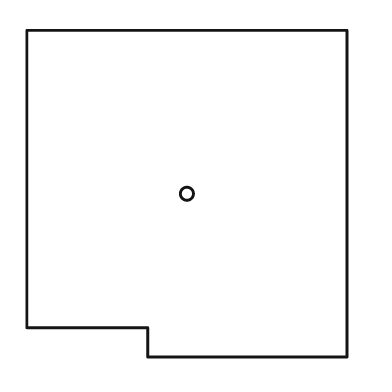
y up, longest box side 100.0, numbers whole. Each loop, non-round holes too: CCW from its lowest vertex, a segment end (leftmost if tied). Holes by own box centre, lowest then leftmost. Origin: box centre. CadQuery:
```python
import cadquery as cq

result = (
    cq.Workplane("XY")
    .moveTo(-12.0, -50.0)
    .lineTo(49.0, -50.0)
    .lineTo(49.0, 50.0)
    .lineTo(-49.0, 50.0)
    .lineTo(-49.0, -41.0)
    .lineTo(-12.0, -41.0)
    .close()
    .moveTo(0.0, 0.0)
    .circle(2.0)
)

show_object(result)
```